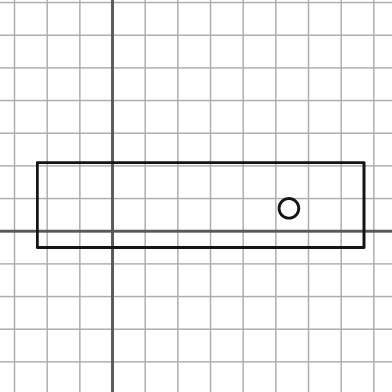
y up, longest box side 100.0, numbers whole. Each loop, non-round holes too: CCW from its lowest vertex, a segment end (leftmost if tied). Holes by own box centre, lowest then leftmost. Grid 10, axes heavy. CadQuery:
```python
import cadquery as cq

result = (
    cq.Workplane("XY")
    .moveTo(-23.0, -5.0)
    .lineTo(77.0, -5.0)
    .lineTo(77.0, 21.0)
    .lineTo(-23.0, 21.0)
    .close()
    .moveTo(54.0, 7.0)
    .circle(3.0)
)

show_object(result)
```